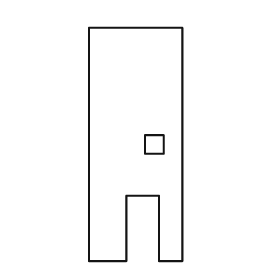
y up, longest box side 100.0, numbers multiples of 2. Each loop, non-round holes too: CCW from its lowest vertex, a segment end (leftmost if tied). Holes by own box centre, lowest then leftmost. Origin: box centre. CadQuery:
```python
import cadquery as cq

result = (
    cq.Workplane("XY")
    .moveTo(-20.0, -50.0)
    .lineTo(-4.0, -50.0)
    .lineTo(-4.0, -22.0)
    .lineTo(10.0, -22.0)
    .lineTo(10.0, -50.0)
    .lineTo(20.0, -50.0)
    .lineTo(20.0, 50.0)
    .lineTo(-20.0, 50.0)
    .close()
    .moveTo(4.0, -4.0)
    .lineTo(12.0, -4.0)
    .lineTo(12.0, 4.0)
    .lineTo(4.0, 4.0)
    .close()
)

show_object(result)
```